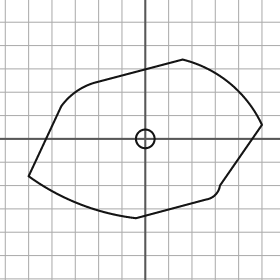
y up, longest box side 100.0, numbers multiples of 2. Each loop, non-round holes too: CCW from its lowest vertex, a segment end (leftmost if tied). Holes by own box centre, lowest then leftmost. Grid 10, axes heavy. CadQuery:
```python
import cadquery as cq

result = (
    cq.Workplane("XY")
    .moveTo(-4.0, -34.0)
    .lineTo(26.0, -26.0)
    .threePointArc((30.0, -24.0), (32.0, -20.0))
    .lineTo(50.0, 6.0)
    .threePointArc((36.0, 24.0), (16.0, 34.0))
    .lineTo(-22.0, 24.0)
    .threePointArc((-30.0, 20.0), (-36.0, 14.0))
    .lineTo(-50.0, -16.0)
    .threePointArc((-28.0, -28.0), (-4.0, -34.0))
    .close()
    .moveTo(0.0, 0.0)
    .circle(4.0)
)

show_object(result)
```